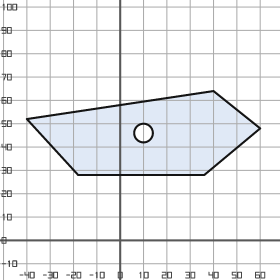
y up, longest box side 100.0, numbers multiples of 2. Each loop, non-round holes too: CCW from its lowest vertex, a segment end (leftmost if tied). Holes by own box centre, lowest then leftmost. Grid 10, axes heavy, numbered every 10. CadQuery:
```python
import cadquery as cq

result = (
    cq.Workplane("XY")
    .moveTo(-18.0, 28.0)
    .lineTo(36.0, 28.0)
    .lineTo(60.0, 48.0)
    .lineTo(40.0, 64.0)
    .lineTo(-40.0, 52.0)
    .close()
    .moveTo(10.0, 46.0)
    .circle(4.0)
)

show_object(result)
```